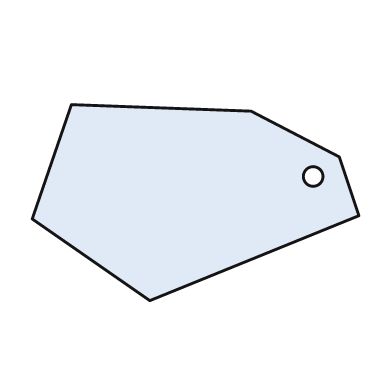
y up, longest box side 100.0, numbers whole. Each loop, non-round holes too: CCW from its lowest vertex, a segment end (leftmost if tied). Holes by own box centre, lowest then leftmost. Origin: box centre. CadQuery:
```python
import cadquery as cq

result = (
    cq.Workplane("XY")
    .moveTo(-14.0, -30.0)
    .lineTo(50.0, -4.0)
    .lineTo(44.0, 14.0)
    .lineTo(17.0, 28.0)
    .lineTo(-38.0, 30.0)
    .lineTo(-50.0, -5.0)
    .close()
    .moveTo(36.0, 8.0)
    .circle(3.0)
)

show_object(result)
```